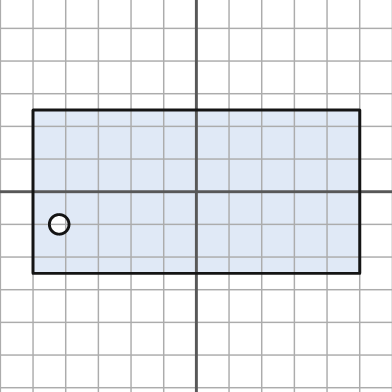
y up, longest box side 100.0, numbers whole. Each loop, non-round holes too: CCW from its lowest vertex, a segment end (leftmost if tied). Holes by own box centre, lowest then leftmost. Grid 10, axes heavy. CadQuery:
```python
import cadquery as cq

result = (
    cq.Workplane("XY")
    .moveTo(-50.0, -25.0)
    .lineTo(50.0, -25.0)
    .lineTo(50.0, 25.0)
    .lineTo(-50.0, 25.0)
    .close()
    .moveTo(-42.0, -10.0)
    .circle(3.0)
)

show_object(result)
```